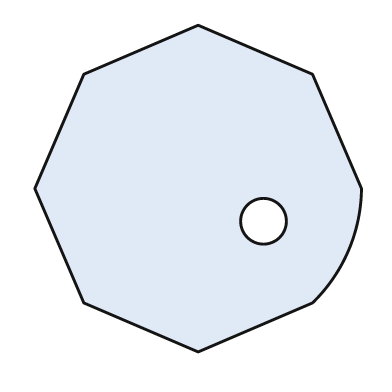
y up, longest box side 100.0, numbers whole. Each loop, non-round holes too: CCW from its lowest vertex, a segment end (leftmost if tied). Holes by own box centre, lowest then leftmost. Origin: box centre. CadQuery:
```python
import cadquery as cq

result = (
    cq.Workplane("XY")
    .moveTo(0.0, -50.0)
    .lineTo(35.0, -35.0)
    .threePointArc((46.0, -19.0), (50.0, 0.0))
    .lineTo(35.0, 35.0)
    .lineTo(0.0, 50.0)
    .lineTo(-35.0, 35.0)
    .lineTo(-50.0, 0.0)
    .lineTo(-35.0, -35.0)
    .close()
    .moveTo(20.0, -10.0)
    .circle(7.0)
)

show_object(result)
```